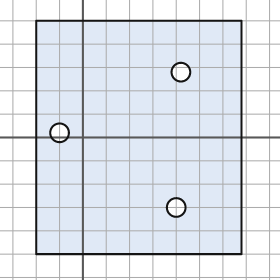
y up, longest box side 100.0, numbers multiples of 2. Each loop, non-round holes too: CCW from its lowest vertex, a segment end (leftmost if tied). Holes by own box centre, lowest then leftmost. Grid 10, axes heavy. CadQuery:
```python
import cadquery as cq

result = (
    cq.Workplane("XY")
    .moveTo(-20.0, -50.0)
    .lineTo(68.0, -50.0)
    .lineTo(68.0, 50.0)
    .lineTo(-20.0, 50.0)
    .close()
    .moveTo(40.0, -30.0)
    .circle(4.0)
    .moveTo(-10.0, 2.0)
    .circle(4.0)
    .moveTo(42.0, 28.0)
    .circle(4.0)
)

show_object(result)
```